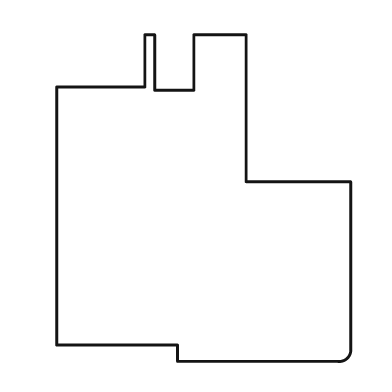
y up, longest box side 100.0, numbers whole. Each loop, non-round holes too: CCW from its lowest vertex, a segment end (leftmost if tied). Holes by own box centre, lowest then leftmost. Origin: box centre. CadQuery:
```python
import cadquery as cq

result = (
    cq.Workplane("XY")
    .moveTo(-8.0, -50.0)
    .lineTo(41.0, -50.0)
    .threePointArc((44.0, -49.0), (45.0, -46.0))
    .lineTo(45.0, 5.0)
    .lineTo(13.0, 5.0)
    .lineTo(13.0, 50.0)
    .lineTo(-3.0, 50.0)
    .lineTo(-3.0, 33.0)
    .lineTo(-15.0, 33.0)
    .lineTo(-15.0, 50.0)
    .lineTo(-18.0, 50.0)
    .lineTo(-18.0, 34.0)
    .lineTo(-45.0, 34.0)
    .lineTo(-45.0, -45.0)
    .lineTo(-8.0, -45.0)
    .close()
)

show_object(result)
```